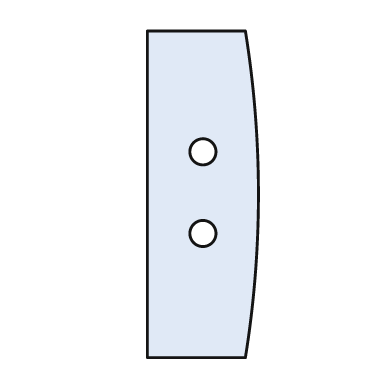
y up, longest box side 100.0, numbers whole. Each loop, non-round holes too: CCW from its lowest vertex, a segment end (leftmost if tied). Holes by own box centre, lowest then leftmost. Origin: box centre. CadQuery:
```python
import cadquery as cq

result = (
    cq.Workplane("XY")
    .moveTo(-17.0, -50.0)
    .lineTo(13.0, -50.0)
    .threePointArc((17.0, 0.0), (13.0, 50.0))
    .lineTo(-17.0, 50.0)
    .close()
    .moveTo(0.0, -12.0)
    .circle(4.0)
    .moveTo(0.0, 13.0)
    .circle(4.0)
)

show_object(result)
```